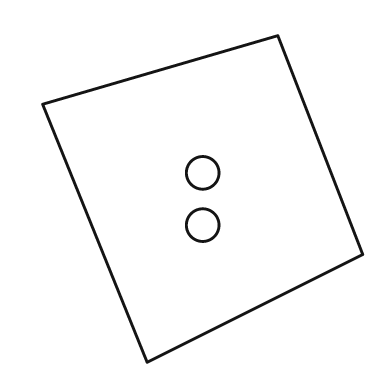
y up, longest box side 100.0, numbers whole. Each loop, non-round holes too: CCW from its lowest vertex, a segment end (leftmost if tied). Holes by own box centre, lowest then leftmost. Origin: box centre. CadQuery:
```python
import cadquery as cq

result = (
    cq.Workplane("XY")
    .moveTo(-17.0, -50.0)
    .lineTo(49.0, -17.0)
    .lineTo(23.0, 50.0)
    .lineTo(-49.0, 29.0)
    .close()
    .moveTo(0.0, -8.0)
    .circle(5.0)
    .moveTo(0.0, 8.0)
    .circle(5.0)
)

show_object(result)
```